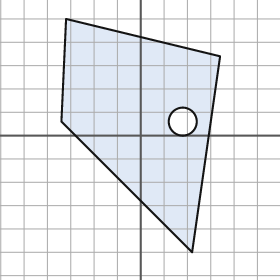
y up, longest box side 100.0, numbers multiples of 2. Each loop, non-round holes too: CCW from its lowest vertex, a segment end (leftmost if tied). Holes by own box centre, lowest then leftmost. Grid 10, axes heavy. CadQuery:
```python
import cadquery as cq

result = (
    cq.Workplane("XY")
    .moveTo(22.0, -50.0)
    .lineTo(34.0, 34.0)
    .lineTo(-32.0, 50.0)
    .lineTo(-34.0, 6.0)
    .close()
    .moveTo(18.0, 6.0)
    .circle(6.0)
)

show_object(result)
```